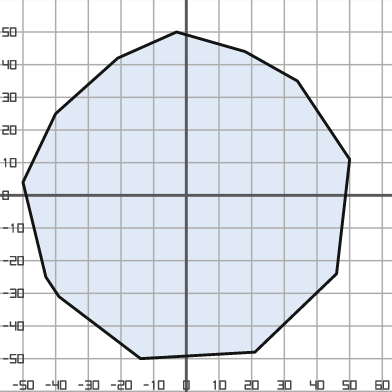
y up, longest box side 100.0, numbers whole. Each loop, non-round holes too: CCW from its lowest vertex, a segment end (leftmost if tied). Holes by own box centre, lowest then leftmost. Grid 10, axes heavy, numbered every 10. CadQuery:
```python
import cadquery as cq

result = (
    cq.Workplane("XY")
    .moveTo(-14.0, -50.0)
    .lineTo(21.0, -48.0)
    .lineTo(46.0, -24.0)
    .lineTo(50.0, 11.0)
    .lineTo(34.0, 35.0)
    .lineTo(18.0, 44.0)
    .lineTo(-3.0, 50.0)
    .lineTo(-21.0, 42.0)
    .lineTo(-40.0, 25.0)
    .lineTo(-50.0, 4.0)
    .lineTo(-43.0, -25.0)
    .lineTo(-39.0, -31.0)
    .close()
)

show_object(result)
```